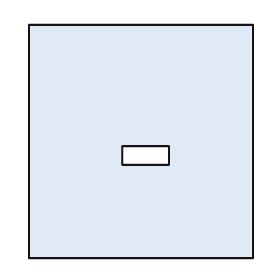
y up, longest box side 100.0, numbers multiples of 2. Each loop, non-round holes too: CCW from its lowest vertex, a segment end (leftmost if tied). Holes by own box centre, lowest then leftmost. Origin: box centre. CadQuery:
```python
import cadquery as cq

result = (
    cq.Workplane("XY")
    .moveTo(-48.0, -50.0)
    .lineTo(48.0, -50.0)
    .lineTo(48.0, 50.0)
    .lineTo(-48.0, 50.0)
    .close()
    .moveTo(-8.0, -10.0)
    .lineTo(12.0, -10.0)
    .lineTo(12.0, -2.0)
    .lineTo(-8.0, -2.0)
    .close()
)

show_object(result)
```